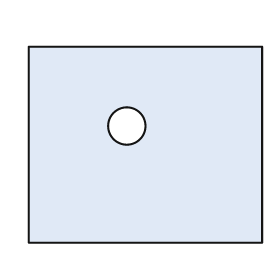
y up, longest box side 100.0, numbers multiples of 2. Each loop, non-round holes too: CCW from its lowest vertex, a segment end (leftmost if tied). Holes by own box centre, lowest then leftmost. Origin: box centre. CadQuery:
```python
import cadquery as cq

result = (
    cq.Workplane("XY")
    .moveTo(-50.0, -42.0)
    .lineTo(50.0, -42.0)
    .lineTo(50.0, 42.0)
    .lineTo(-50.0, 42.0)
    .close()
    .moveTo(-8.0, 8.0)
    .circle(8.0)
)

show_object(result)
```